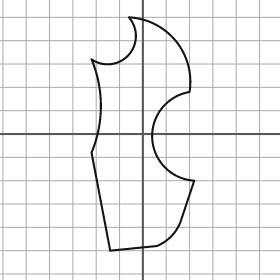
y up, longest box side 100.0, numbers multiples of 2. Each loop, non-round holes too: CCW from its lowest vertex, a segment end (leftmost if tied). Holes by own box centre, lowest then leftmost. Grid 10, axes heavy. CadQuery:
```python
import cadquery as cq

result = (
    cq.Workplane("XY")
    .moveTo(-14.0, -50.0)
    .lineTo(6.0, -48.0)
    .threePointArc((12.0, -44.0), (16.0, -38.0))
    .lineTo(22.0, -20.0)
    .threePointArc((4.0, -2.0), (20.0, 18.0))
    .threePointArc((14.0, 40.0), (-6.0, 50.0))
    .threePointArc((-6.0, 34.0), (-22.0, 32.0))
    .threePointArc((-18.0, 12.0), (-22.0, -8.0))
    .close()
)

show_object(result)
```